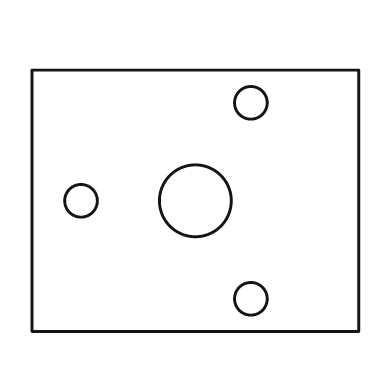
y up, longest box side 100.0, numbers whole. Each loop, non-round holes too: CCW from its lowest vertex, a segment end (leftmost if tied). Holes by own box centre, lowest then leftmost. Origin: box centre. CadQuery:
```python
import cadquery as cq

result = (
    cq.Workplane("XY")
    .moveTo(-50.0, -40.0)
    .lineTo(50.0, -40.0)
    .lineTo(50.0, 40.0)
    .lineTo(-50.0, 40.0)
    .close()
    .moveTo(17.0, -30.0)
    .circle(5.0)
    .moveTo(-35.0, 0.0)
    .circle(5.0)
    .moveTo(0.0, 0.0)
    .circle(11.0)
    .moveTo(17.0, 30.0)
    .circle(5.0)
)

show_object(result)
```